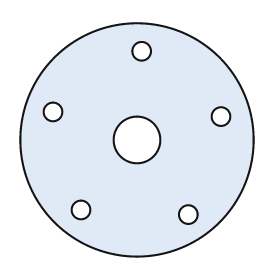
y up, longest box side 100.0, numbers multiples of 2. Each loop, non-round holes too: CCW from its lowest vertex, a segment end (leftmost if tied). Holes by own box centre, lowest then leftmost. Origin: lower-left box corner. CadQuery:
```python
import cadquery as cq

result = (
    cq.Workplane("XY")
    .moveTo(50.0, 50.0)
    .circle(50.0)
    .moveTo(72.0, 18.0)
    .circle(4.0)
    .moveTo(26.0, 20.0)
    .circle(4.0)
    .moveTo(50.0, 50.0)
    .circle(10.0)
    .moveTo(86.0, 60.0)
    .circle(4.0)
    .moveTo(14.0, 62.0)
    .circle(4.0)
    .moveTo(52.0, 88.0)
    .circle(4.0)
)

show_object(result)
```